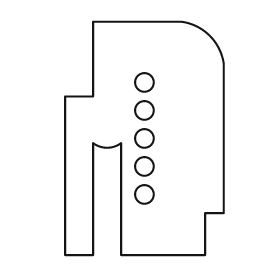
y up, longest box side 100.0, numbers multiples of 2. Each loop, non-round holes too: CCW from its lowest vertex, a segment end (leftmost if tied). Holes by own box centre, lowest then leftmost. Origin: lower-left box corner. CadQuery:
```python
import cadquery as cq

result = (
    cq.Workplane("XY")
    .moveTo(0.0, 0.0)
    .lineTo(12.0, 0.0)
    .lineTo(12.0, 48.0)
    .threePointArc((18.0, 46.0), (24.0, 48.0))
    .lineTo(24.0, 0.0)
    .lineTo(60.0, 0.0)
    .lineTo(60.0, 18.0)
    .lineTo(68.0, 18.0)
    .lineTo(68.0, 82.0)
    .threePointArc((62.0, 94.0), (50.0, 100.0))
    .lineTo(12.0, 100.0)
    .lineTo(12.0, 68.0)
    .lineTo(0.0, 68.0)
    .close()
    .moveTo(34.0, 26.0)
    .circle(4.0)
    .moveTo(34.0, 38.0)
    .circle(4.0)
    .moveTo(34.0, 50.0)
    .circle(4.0)
    .moveTo(34.0, 62.0)
    .circle(4.0)
    .moveTo(34.0, 74.0)
    .circle(4.0)
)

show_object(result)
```